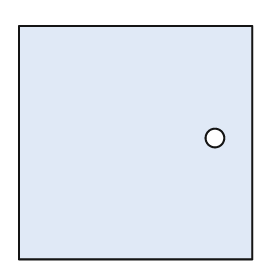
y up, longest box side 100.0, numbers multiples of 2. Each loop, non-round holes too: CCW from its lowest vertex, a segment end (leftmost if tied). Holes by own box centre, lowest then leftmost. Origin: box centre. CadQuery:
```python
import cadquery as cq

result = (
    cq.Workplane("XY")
    .moveTo(-50.0, -50.0)
    .lineTo(50.0, -50.0)
    .lineTo(50.0, 50.0)
    .lineTo(-50.0, 50.0)
    .close()
    .moveTo(34.0, 2.0)
    .circle(4.0)
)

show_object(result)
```